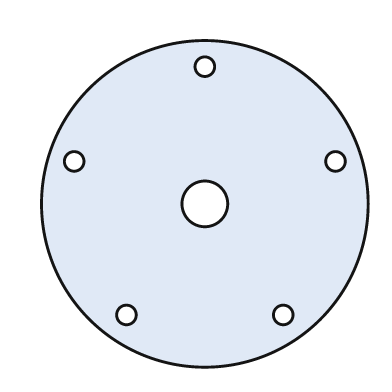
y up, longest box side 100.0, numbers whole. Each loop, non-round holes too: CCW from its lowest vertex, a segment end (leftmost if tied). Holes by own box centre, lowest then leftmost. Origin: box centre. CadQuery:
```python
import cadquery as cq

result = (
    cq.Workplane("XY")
    .moveTo(0.0, 0.0)
    .circle(50.0)
    .moveTo(-24.0, -34.0)
    .circle(3.0)
    .moveTo(24.0, -34.0)
    .circle(3.0)
    .moveTo(0.0, 0.0)
    .circle(7.0)
    .moveTo(-40.0, 13.0)
    .circle(3.0)
    .moveTo(40.0, 13.0)
    .circle(3.0)
    .moveTo(0.0, 42.0)
    .circle(3.0)
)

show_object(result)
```